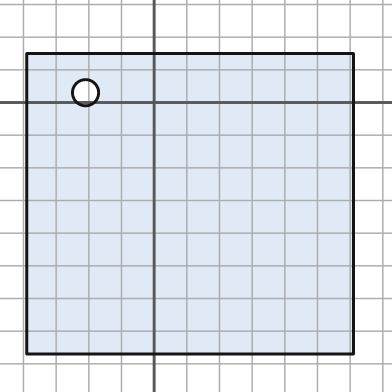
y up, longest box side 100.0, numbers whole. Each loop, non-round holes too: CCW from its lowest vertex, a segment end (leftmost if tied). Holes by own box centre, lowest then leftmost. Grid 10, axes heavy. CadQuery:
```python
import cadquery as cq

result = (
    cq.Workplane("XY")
    .moveTo(-39.0, -77.0)
    .lineTo(61.0, -77.0)
    .lineTo(61.0, 15.0)
    .lineTo(-39.0, 15.0)
    .close()
    .moveTo(-21.0, 3.0)
    .circle(4.0)
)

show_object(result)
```